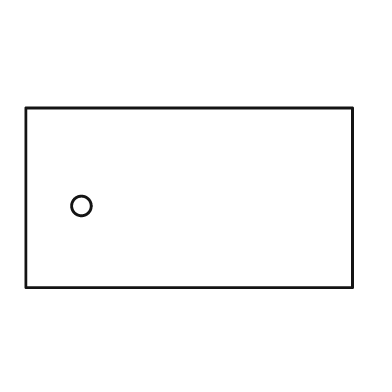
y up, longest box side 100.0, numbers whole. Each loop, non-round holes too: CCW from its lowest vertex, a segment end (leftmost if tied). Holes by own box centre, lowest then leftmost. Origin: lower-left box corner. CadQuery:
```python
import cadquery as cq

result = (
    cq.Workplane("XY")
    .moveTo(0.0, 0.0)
    .lineTo(100.0, 0.0)
    .lineTo(100.0, 55.0)
    .lineTo(0.0, 55.0)
    .close()
    .moveTo(17.0, 25.0)
    .circle(3.0)
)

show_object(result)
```